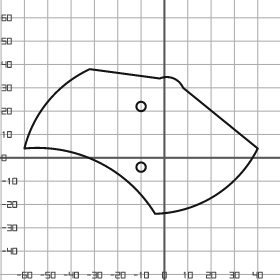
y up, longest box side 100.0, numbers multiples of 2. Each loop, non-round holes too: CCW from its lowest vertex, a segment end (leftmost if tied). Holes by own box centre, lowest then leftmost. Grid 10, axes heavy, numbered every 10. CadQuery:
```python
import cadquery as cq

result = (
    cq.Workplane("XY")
    .moveTo(-4.0, -24.0)
    .threePointArc((22.0, -16.0), (40.0, 4.0))
    .lineTo(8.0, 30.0)
    .threePointArc((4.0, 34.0), (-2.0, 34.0))
    .lineTo(-32.0, 38.0)
    .threePointArc((-50.0, 24.0), (-60.0, 4.0))
    .threePointArc((-28.0, -2.0), (-4.0, -24.0))
    .close()
    .moveTo(-10.0, -4.0)
    .circle(2.0)
    .moveTo(-10.0, 22.0)
    .circle(2.0)
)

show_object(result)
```